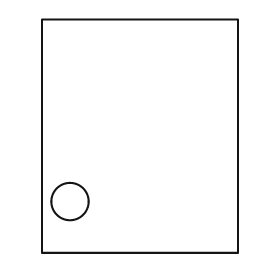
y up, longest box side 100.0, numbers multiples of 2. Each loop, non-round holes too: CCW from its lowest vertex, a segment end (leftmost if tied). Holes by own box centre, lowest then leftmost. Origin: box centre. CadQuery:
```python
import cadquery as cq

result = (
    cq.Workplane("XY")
    .moveTo(-42.0, -50.0)
    .lineTo(42.0, -50.0)
    .lineTo(42.0, 50.0)
    .lineTo(-42.0, 50.0)
    .close()
    .moveTo(-30.0, -28.0)
    .circle(8.0)
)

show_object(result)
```